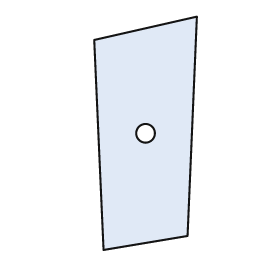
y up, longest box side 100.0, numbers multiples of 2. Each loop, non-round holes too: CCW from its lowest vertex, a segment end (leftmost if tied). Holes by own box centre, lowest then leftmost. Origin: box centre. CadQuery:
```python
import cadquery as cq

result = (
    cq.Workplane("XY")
    .moveTo(-18.0, -50.0)
    .lineTo(18.0, -44.0)
    .lineTo(22.0, 50.0)
    .lineTo(-22.0, 40.0)
    .close()
    .moveTo(0.0, 0.0)
    .circle(4.0)
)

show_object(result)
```